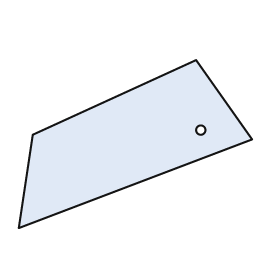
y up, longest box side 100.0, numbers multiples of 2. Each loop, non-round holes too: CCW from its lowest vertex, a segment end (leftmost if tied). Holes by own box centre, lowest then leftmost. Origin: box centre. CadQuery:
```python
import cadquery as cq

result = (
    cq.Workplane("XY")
    .moveTo(-50.0, -36.0)
    .lineTo(50.0, 2.0)
    .lineTo(26.0, 36.0)
    .lineTo(-44.0, 4.0)
    .close()
    .moveTo(28.0, 6.0)
    .circle(2.0)
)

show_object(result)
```